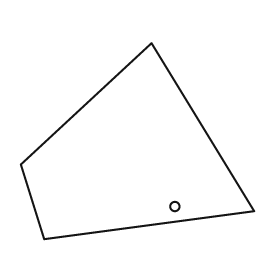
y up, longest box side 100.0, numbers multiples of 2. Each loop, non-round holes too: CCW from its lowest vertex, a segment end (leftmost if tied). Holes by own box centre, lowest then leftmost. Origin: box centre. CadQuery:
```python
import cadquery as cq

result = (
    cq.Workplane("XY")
    .moveTo(-40.0, -42.0)
    .lineTo(50.0, -30.0)
    .lineTo(6.0, 42.0)
    .lineTo(-50.0, -10.0)
    .close()
    .moveTo(16.0, -28.0)
    .circle(2.0)
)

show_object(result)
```